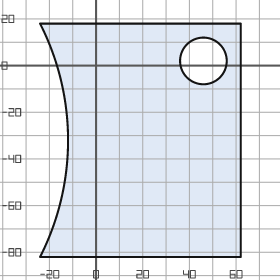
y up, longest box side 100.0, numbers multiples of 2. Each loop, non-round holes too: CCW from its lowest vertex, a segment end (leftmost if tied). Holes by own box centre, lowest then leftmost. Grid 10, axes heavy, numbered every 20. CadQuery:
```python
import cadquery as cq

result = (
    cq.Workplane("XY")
    .moveTo(-24.0, -82.0)
    .lineTo(62.0, -82.0)
    .lineTo(62.0, 18.0)
    .lineTo(-24.0, 18.0)
    .threePointArc((-12.0, -32.0), (-24.0, -82.0))
    .close()
    .moveTo(46.0, 2.0)
    .circle(10.0)
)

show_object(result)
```